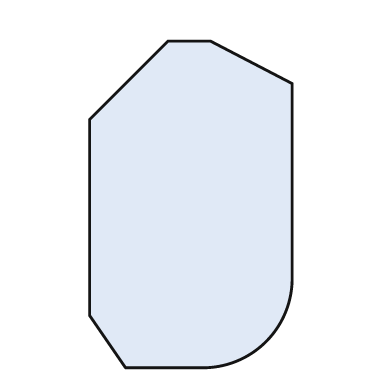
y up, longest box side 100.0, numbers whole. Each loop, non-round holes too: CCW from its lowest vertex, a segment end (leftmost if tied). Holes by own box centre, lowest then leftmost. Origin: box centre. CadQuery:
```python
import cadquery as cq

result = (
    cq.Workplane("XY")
    .moveTo(-20.0, -50.0)
    .lineTo(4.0, -50.0)
    .threePointArc((23.0, -42.0), (31.0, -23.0))
    .lineTo(31.0, 37.0)
    .lineTo(6.0, 50.0)
    .lineTo(-7.0, 50.0)
    .lineTo(-31.0, 26.0)
    .lineTo(-31.0, -34.0)
    .close()
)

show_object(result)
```